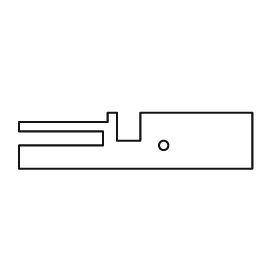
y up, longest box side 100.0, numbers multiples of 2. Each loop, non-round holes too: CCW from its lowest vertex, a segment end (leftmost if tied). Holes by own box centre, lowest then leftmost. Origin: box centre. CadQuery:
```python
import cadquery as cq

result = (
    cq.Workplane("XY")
    .moveTo(-50.0, -12.0)
    .lineTo(50.0, -12.0)
    .lineTo(50.0, 12.0)
    .lineTo(2.0, 12.0)
    .lineTo(2.0, 0.0)
    .lineTo(-8.0, 0.0)
    .lineTo(-8.0, 12.0)
    .lineTo(-12.0, 12.0)
    .lineTo(-12.0, 8.0)
    .lineTo(-50.0, 8.0)
    .lineTo(-50.0, 4.0)
    .lineTo(-14.0, 4.0)
    .lineTo(-14.0, -2.0)
    .lineTo(-50.0, -2.0)
    .close()
    .moveTo(12.0, -2.0)
    .circle(2.0)
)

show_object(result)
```